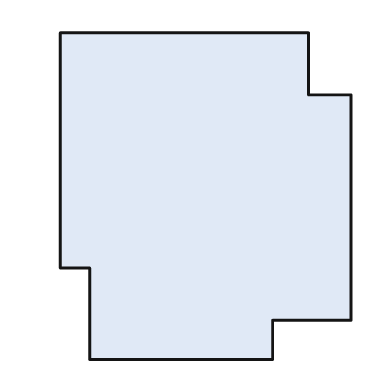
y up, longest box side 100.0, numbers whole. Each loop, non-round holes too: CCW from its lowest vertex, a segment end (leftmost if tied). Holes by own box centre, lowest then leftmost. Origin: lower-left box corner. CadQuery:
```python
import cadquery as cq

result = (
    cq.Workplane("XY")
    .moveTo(9.0, 0.0)
    .lineTo(65.0, 0.0)
    .lineTo(65.0, 12.0)
    .lineTo(89.0, 12.0)
    .lineTo(89.0, 81.0)
    .lineTo(76.0, 81.0)
    .lineTo(76.0, 100.0)
    .lineTo(0.0, 100.0)
    .lineTo(0.0, 28.0)
    .lineTo(9.0, 28.0)
    .close()
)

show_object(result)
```